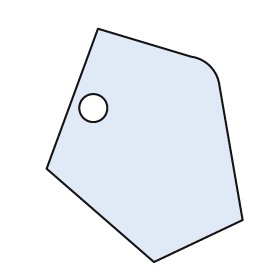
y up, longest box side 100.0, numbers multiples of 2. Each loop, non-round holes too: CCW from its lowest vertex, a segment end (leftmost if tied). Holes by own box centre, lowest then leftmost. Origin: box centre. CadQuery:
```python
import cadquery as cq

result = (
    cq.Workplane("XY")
    .moveTo(4.0, -50.0)
    .lineTo(42.0, -32.0)
    .lineTo(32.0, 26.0)
    .threePointArc((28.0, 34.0), (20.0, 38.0))
    .lineTo(-20.0, 50.0)
    .lineTo(-42.0, -10.0)
    .close()
    .moveTo(-22.0, 16.0)
    .circle(6.0)
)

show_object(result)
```